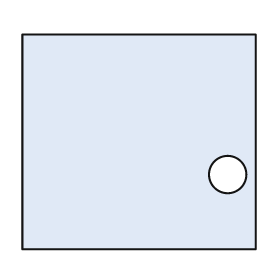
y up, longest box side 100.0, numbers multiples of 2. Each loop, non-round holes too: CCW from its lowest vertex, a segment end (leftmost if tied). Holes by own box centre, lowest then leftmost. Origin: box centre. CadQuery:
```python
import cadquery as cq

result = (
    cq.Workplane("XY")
    .moveTo(-50.0, -46.0)
    .lineTo(50.0, -46.0)
    .lineTo(50.0, 46.0)
    .lineTo(-50.0, 46.0)
    .close()
    .moveTo(38.0, -14.0)
    .circle(8.0)
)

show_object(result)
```